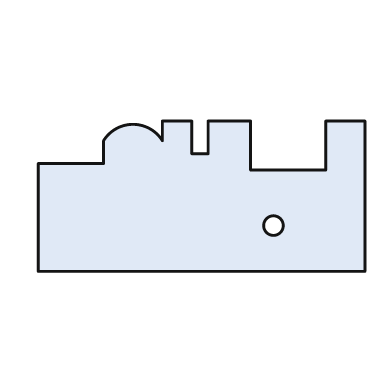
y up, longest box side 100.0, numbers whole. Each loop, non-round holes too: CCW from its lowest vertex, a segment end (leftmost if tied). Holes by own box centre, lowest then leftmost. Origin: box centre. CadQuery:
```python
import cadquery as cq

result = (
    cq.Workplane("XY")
    .moveTo(-50.0, -23.0)
    .lineTo(50.0, -23.0)
    .lineTo(50.0, 23.0)
    .lineTo(38.0, 23.0)
    .lineTo(38.0, 8.0)
    .lineTo(15.0, 8.0)
    .lineTo(15.0, 23.0)
    .lineTo(2.0, 23.0)
    .lineTo(2.0, 13.0)
    .lineTo(-3.0, 13.0)
    .lineTo(-3.0, 23.0)
    .lineTo(-12.0, 23.0)
    .lineTo(-12.0, 17.0)
    .threePointArc((-21.0, 22.0), (-30.0, 17.0))
    .lineTo(-30.0, 10.0)
    .lineTo(-50.0, 10.0)
    .close()
    .moveTo(22.0, -9.0)
    .circle(3.0)
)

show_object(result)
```